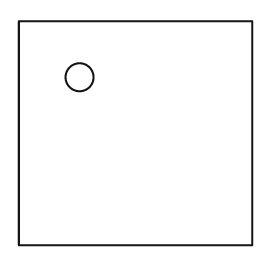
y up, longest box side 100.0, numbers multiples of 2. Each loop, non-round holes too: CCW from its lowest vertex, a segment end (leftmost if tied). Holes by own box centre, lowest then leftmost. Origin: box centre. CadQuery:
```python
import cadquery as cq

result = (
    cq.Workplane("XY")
    .moveTo(-50.0, -48.0)
    .lineTo(50.0, -48.0)
    .lineTo(50.0, 48.0)
    .lineTo(-50.0, 48.0)
    .close()
    .moveTo(-24.0, 24.0)
    .circle(6.0)
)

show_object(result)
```